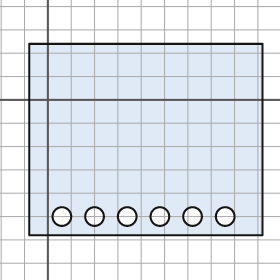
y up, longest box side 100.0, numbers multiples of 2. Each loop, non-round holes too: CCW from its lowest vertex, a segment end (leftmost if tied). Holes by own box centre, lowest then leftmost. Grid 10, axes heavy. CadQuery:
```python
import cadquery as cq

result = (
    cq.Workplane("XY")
    .moveTo(-8.0, -58.0)
    .lineTo(92.0, -58.0)
    .lineTo(92.0, 24.0)
    .lineTo(-8.0, 24.0)
    .close()
    .moveTo(6.0, -50.0)
    .circle(4.0)
    .moveTo(20.0, -50.0)
    .circle(4.0)
    .moveTo(34.0, -50.0)
    .circle(4.0)
    .moveTo(48.0, -50.0)
    .circle(4.0)
    .moveTo(62.0, -50.0)
    .circle(4.0)
    .moveTo(76.0, -50.0)
    .circle(4.0)
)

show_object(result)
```